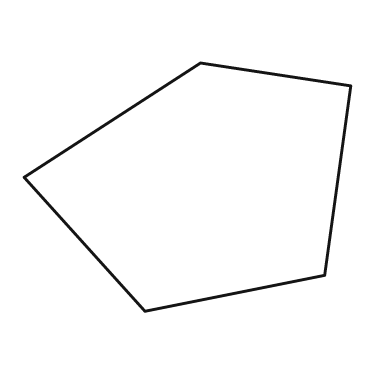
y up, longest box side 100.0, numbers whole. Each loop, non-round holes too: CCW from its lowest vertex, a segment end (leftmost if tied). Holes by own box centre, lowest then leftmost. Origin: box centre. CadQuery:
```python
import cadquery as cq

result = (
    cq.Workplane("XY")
    .moveTo(-13.0, -38.0)
    .lineTo(42.0, -27.0)
    .lineTo(50.0, 31.0)
    .lineTo(4.0, 38.0)
    .lineTo(-50.0, 3.0)
    .close()
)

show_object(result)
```